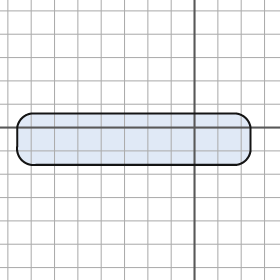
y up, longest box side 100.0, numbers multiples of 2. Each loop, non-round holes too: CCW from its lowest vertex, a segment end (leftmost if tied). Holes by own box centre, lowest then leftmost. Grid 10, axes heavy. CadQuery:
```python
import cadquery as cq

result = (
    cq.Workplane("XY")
    .moveTo(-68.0, -16.0)
    .lineTo(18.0, -16.0)
    .threePointArc((22.0, -14.0), (24.0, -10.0))
    .lineTo(24.0, 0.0)
    .threePointArc((22.0, 4.0), (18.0, 6.0))
    .lineTo(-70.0, 6.0)
    .threePointArc((-74.0, 4.0), (-76.0, 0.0))
    .lineTo(-76.0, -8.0)
    .threePointArc((-74.0, -14.0), (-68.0, -16.0))
    .close()
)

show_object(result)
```